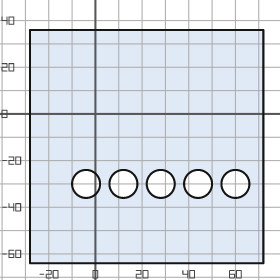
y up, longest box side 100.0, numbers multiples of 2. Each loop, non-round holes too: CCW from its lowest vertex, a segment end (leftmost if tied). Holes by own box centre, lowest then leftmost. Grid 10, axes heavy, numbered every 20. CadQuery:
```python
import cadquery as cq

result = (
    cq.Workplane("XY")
    .moveTo(-28.0, -64.0)
    .lineTo(72.0, -64.0)
    .lineTo(72.0, 36.0)
    .lineTo(-28.0, 36.0)
    .close()
    .moveTo(-4.0, -30.0)
    .circle(6.0)
    .moveTo(12.0, -30.0)
    .circle(6.0)
    .moveTo(28.0, -30.0)
    .circle(6.0)
    .moveTo(44.0, -30.0)
    .circle(6.0)
    .moveTo(60.0, -30.0)
    .circle(6.0)
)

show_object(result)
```